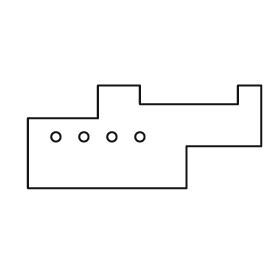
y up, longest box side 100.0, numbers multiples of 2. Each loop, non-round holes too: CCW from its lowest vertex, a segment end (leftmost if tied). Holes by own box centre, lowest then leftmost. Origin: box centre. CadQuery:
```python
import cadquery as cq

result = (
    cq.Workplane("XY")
    .moveTo(-50.0, -22.0)
    .lineTo(18.0, -22.0)
    .lineTo(18.0, -4.0)
    .lineTo(50.0, -4.0)
    .lineTo(50.0, 22.0)
    .lineTo(40.0, 22.0)
    .lineTo(40.0, 14.0)
    .lineTo(-2.0, 14.0)
    .lineTo(-2.0, 22.0)
    .lineTo(-20.0, 22.0)
    .lineTo(-20.0, 8.0)
    .lineTo(-50.0, 8.0)
    .close()
    .moveTo(-38.0, 0.0)
    .circle(2.0)
    .moveTo(-26.0, 0.0)
    .circle(2.0)
    .moveTo(-14.0, 0.0)
    .circle(2.0)
    .moveTo(-2.0, 0.0)
    .circle(2.0)
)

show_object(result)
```